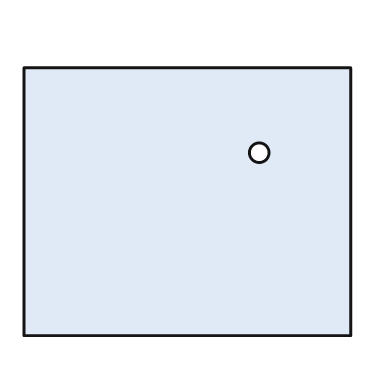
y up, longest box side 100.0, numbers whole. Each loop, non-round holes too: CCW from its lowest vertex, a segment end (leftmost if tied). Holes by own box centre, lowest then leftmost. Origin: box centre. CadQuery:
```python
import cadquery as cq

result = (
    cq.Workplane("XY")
    .moveTo(-50.0, -41.0)
    .lineTo(50.0, -41.0)
    .lineTo(50.0, 41.0)
    .lineTo(-50.0, 41.0)
    .close()
    .moveTo(22.0, 15.0)
    .circle(3.0)
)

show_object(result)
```